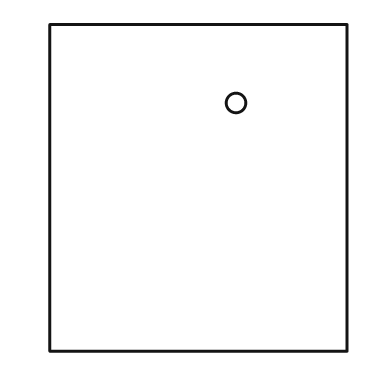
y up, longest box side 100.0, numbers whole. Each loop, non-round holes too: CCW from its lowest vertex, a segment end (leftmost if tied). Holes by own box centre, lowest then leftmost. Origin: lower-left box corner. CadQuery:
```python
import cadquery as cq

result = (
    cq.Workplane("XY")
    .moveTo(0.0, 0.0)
    .lineTo(91.0, 0.0)
    .lineTo(91.0, 100.0)
    .lineTo(0.0, 100.0)
    .close()
    .moveTo(57.0, 76.0)
    .circle(3.0)
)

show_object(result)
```